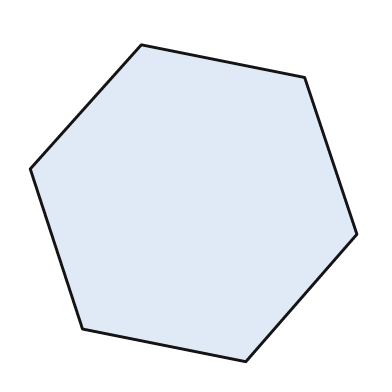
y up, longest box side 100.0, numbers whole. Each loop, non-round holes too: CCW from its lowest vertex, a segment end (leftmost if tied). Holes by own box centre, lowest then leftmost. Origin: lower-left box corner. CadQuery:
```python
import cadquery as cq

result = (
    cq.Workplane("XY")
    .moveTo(66.0, 0.0)
    .lineTo(100.0, 39.0)
    .lineTo(84.0, 87.0)
    .lineTo(34.0, 97.0)
    .lineTo(0.0, 59.0)
    .lineTo(16.0, 10.0)
    .close()
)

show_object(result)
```